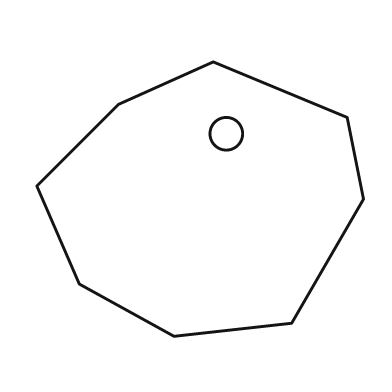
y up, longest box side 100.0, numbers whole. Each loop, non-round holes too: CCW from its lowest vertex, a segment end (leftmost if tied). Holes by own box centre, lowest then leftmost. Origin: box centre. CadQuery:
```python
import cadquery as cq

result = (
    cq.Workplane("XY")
    .moveTo(-8.0, -42.0)
    .lineTo(28.0, -38.0)
    .lineTo(50.0, 0.0)
    .lineTo(45.0, 25.0)
    .lineTo(4.0, 42.0)
    .lineTo(-25.0, 29.0)
    .lineTo(-50.0, 4.0)
    .lineTo(-37.0, -26.0)
    .close()
    .moveTo(8.0, 20.0)
    .circle(5.0)
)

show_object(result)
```